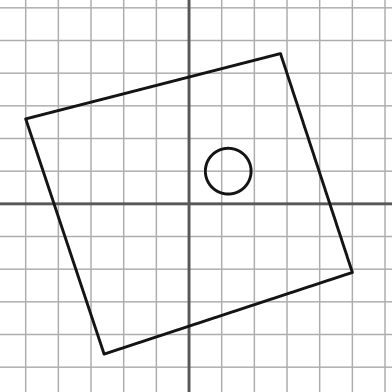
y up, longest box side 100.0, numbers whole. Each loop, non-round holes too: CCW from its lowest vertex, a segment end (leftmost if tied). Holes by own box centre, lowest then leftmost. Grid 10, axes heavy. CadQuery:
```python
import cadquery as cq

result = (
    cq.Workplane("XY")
    .moveTo(-26.0, -46.0)
    .lineTo(50.0, -21.0)
    .lineTo(28.0, 46.0)
    .lineTo(-50.0, 26.0)
    .close()
    .moveTo(12.0, 10.0)
    .circle(7.0)
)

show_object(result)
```